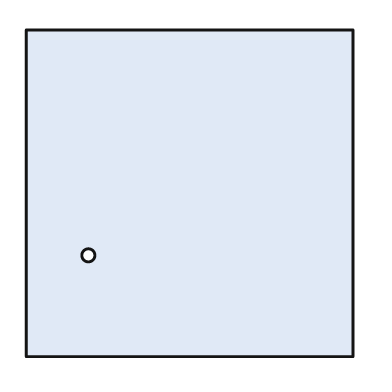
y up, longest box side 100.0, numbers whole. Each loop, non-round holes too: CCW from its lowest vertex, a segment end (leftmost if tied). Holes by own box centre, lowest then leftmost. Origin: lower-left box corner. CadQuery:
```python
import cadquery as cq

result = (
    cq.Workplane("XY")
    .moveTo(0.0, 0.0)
    .lineTo(100.0, 0.0)
    .lineTo(100.0, 100.0)
    .lineTo(0.0, 100.0)
    .close()
    .moveTo(19.0, 31.0)
    .circle(2.0)
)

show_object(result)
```